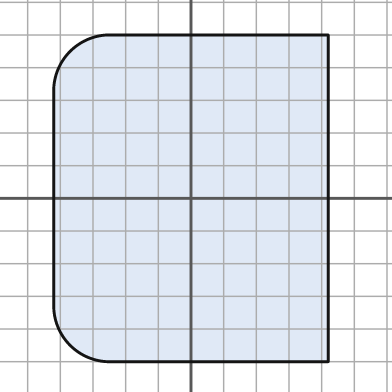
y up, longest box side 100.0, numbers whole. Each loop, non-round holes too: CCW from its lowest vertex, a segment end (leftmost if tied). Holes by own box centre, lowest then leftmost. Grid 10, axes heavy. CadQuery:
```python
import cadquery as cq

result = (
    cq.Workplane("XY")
    .moveTo(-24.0, -50.0)
    .lineTo(42.0, -50.0)
    .lineTo(42.0, 50.0)
    .lineTo(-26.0, 50.0)
    .threePointArc((-37.0, 45.0), (-42.0, 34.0))
    .lineTo(-42.0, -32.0)
    .threePointArc((-37.0, -45.0), (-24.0, -50.0))
    .close()
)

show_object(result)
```